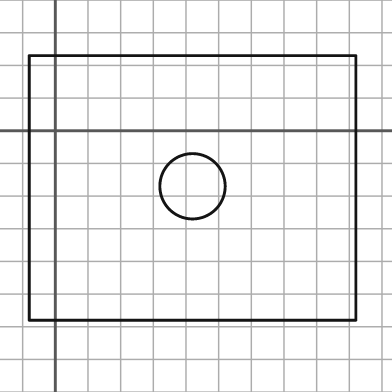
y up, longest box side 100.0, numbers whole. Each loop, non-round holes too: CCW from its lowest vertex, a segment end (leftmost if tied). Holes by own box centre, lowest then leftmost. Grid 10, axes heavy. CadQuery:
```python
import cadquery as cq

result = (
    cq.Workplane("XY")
    .moveTo(-8.0, -58.0)
    .lineTo(92.0, -58.0)
    .lineTo(92.0, 23.0)
    .lineTo(-8.0, 23.0)
    .close()
    .moveTo(42.0, -17.0)
    .circle(10.0)
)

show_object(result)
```